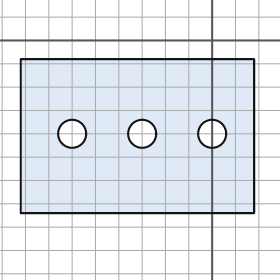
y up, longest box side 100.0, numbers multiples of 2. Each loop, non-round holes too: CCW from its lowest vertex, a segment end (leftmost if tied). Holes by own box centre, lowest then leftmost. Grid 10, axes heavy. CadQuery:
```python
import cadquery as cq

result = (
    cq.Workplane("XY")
    .moveTo(-82.0, -74.0)
    .lineTo(18.0, -74.0)
    .lineTo(18.0, -8.0)
    .lineTo(-82.0, -8.0)
    .close()
    .moveTo(-60.0, -40.0)
    .circle(6.0)
    .moveTo(-30.0, -40.0)
    .circle(6.0)
    .moveTo(0.0, -40.0)
    .circle(6.0)
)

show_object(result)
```